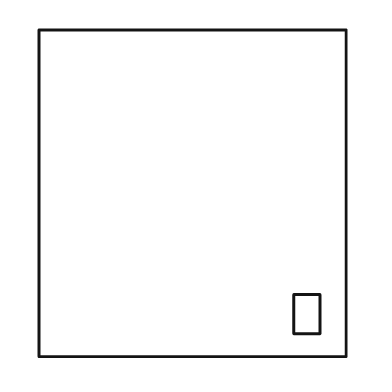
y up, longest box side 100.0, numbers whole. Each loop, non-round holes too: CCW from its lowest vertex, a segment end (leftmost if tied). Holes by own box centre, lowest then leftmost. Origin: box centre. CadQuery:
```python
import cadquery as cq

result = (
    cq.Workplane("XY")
    .moveTo(-47.0, -50.0)
    .lineTo(47.0, -50.0)
    .lineTo(47.0, 50.0)
    .lineTo(-47.0, 50.0)
    .close()
    .moveTo(31.0, -43.0)
    .lineTo(39.0, -43.0)
    .lineTo(39.0, -31.0)
    .lineTo(31.0, -31.0)
    .close()
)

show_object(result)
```